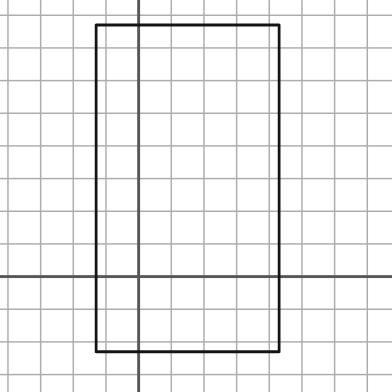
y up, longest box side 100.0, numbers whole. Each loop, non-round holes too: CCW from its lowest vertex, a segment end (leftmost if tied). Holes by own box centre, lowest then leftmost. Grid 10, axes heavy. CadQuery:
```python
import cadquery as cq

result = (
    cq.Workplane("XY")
    .moveTo(-13.0, -23.0)
    .lineTo(43.0, -23.0)
    .lineTo(43.0, 77.0)
    .lineTo(-13.0, 77.0)
    .close()
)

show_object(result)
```